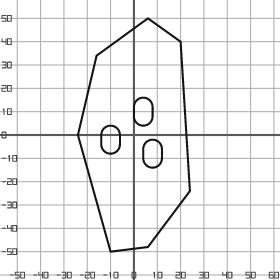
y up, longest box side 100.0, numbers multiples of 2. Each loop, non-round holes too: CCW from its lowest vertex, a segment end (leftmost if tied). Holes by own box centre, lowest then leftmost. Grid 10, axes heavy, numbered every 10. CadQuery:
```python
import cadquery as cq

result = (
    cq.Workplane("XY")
    .moveTo(-10.0, -50.0)
    .lineTo(6.0, -48.0)
    .lineTo(24.0, -24.0)
    .lineTo(20.0, 40.0)
    .lineTo(6.0, 50.0)
    .lineTo(-16.0, 34.0)
    .lineTo(-24.0, 0.0)
    .close()
    .moveTo(4.0, -10.0)
    .threePointArc((8.0, -14.0), (12.0, -10.0))
    .lineTo(12.0, -6.0)
    .threePointArc((8.0, -2.0), (4.0, -6.0))
    .close()
    .moveTo(-14.0, -4.0)
    .threePointArc((-10.0, -8.0), (-6.0, -4.0))
    .lineTo(-6.0, 0.0)
    .threePointArc((-10.0, 4.0), (-14.0, 0.0))
    .close()
    .moveTo(0.0, 8.0)
    .threePointArc((4.0, 4.0), (8.0, 8.0))
    .lineTo(8.0, 12.0)
    .threePointArc((4.0, 16.0), (0.0, 12.0))
    .close()
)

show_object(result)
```